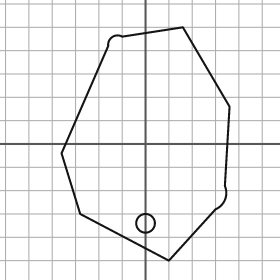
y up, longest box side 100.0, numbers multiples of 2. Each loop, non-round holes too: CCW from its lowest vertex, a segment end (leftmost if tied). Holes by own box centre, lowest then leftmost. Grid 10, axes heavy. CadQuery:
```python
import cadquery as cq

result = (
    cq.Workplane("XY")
    .moveTo(10.0, -50.0)
    .lineTo(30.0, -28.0)
    .threePointArc((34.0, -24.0), (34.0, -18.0))
    .lineTo(36.0, 16.0)
    .lineTo(16.0, 50.0)
    .lineTo(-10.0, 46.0)
    .threePointArc((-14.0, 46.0), (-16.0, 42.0))
    .lineTo(-36.0, -4.0)
    .lineTo(-28.0, -30.0)
    .close()
    .moveTo(0.0, -34.0)
    .circle(4.0)
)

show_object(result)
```